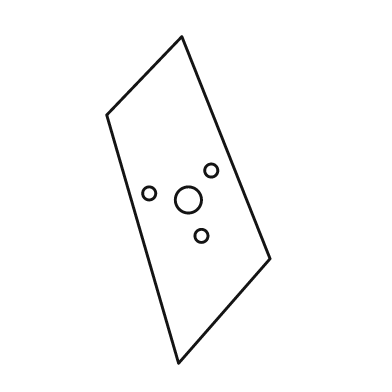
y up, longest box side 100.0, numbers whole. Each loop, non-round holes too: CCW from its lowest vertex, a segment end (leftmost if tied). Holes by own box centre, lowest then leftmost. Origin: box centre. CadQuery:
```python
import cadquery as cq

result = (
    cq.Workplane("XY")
    .moveTo(-3.0, -50.0)
    .lineTo(25.0, -18.0)
    .lineTo(-2.0, 50.0)
    .lineTo(-25.0, 26.0)
    .close()
    .moveTo(4.0, -11.0)
    .circle(2.0)
    .moveTo(0.0, 0.0)
    .circle(4.0)
    .moveTo(-12.0, 2.0)
    .circle(2.0)
    .moveTo(7.0, 9.0)
    .circle(2.0)
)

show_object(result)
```